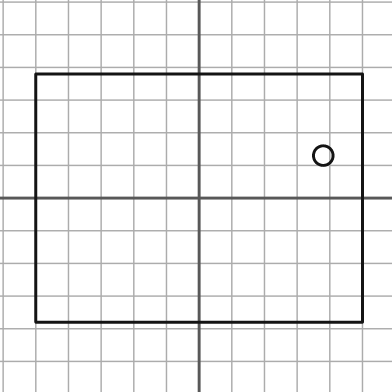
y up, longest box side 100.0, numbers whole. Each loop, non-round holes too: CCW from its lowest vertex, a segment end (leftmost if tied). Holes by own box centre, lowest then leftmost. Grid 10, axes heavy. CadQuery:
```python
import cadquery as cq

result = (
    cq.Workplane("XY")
    .moveTo(-50.0, -38.0)
    .lineTo(50.0, -38.0)
    .lineTo(50.0, 38.0)
    .lineTo(-50.0, 38.0)
    .close()
    .moveTo(38.0, 13.0)
    .circle(3.0)
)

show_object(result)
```